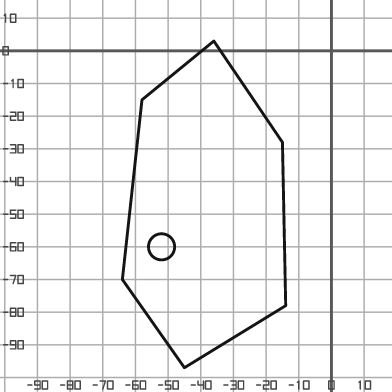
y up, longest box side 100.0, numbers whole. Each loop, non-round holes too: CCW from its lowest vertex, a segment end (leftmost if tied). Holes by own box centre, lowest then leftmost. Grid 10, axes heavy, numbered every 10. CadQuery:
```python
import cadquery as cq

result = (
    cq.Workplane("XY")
    .moveTo(-45.0, -97.0)
    .lineTo(-14.0, -78.0)
    .lineTo(-15.0, -28.0)
    .lineTo(-36.0, 3.0)
    .lineTo(-58.0, -15.0)
    .lineTo(-64.0, -70.0)
    .close()
    .moveTo(-52.0, -60.0)
    .circle(4.0)
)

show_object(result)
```